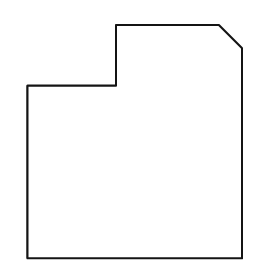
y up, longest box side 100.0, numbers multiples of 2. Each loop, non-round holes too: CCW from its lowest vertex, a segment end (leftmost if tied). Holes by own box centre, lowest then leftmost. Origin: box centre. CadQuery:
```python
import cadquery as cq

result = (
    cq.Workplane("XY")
    .moveTo(-46.0, -50.0)
    .lineTo(46.0, -50.0)
    .lineTo(46.0, 40.0)
    .lineTo(36.0, 50.0)
    .lineTo(-8.0, 50.0)
    .lineTo(-8.0, 24.0)
    .lineTo(-46.0, 24.0)
    .close()
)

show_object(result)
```